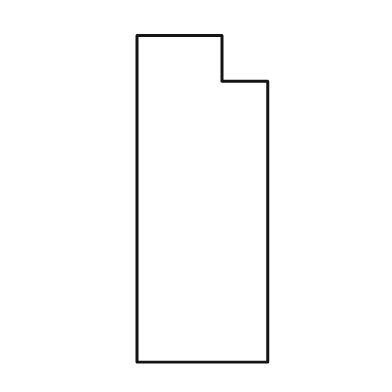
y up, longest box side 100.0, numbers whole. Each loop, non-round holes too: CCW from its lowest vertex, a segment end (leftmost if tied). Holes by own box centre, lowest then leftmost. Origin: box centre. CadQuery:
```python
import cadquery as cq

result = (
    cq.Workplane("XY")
    .moveTo(-20.0, -50.0)
    .lineTo(20.0, -50.0)
    .lineTo(20.0, 36.0)
    .lineTo(6.0, 36.0)
    .lineTo(6.0, 50.0)
    .lineTo(-20.0, 50.0)
    .close()
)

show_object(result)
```